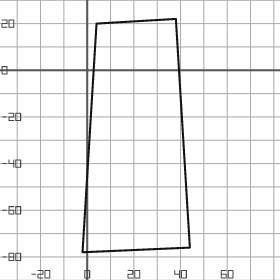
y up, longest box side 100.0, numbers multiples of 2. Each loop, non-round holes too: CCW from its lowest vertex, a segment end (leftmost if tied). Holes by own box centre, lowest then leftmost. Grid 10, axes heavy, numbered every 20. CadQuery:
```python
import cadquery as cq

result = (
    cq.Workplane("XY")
    .moveTo(-2.0, -78.0)
    .lineTo(44.0, -76.0)
    .lineTo(38.0, 22.0)
    .lineTo(4.0, 20.0)
    .close()
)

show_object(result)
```